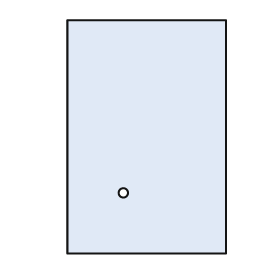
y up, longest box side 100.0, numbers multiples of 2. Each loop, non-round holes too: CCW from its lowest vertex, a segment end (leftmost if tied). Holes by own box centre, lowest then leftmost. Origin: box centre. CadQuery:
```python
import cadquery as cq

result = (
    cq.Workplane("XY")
    .moveTo(-34.0, -50.0)
    .lineTo(34.0, -50.0)
    .lineTo(34.0, 50.0)
    .lineTo(-34.0, 50.0)
    .close()
    .moveTo(-10.0, -24.0)
    .circle(2.0)
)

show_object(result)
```